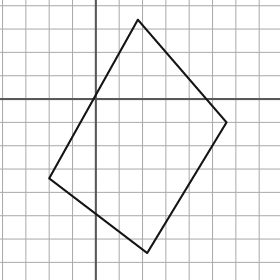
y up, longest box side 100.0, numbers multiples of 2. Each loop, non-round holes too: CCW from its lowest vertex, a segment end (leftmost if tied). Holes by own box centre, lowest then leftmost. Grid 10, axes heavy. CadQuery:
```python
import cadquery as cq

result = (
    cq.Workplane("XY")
    .moveTo(22.0, -66.0)
    .lineTo(56.0, -10.0)
    .lineTo(18.0, 34.0)
    .lineTo(-20.0, -34.0)
    .close()
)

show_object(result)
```